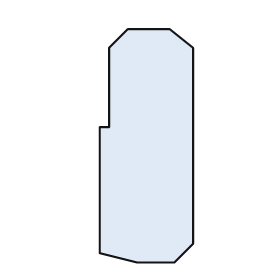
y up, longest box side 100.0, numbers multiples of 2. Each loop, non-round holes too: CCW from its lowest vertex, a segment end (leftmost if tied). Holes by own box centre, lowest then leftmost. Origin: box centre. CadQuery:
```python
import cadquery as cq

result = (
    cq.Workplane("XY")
    .moveTo(-4.0, -50.0)
    .lineTo(12.0, -50.0)
    .lineTo(20.0, -42.0)
    .lineTo(20.0, 42.0)
    .lineTo(10.0, 50.0)
    .lineTo(-8.0, 50.0)
    .lineTo(-16.0, 42.0)
    .lineTo(-16.0, 8.0)
    .lineTo(-20.0, 8.0)
    .lineTo(-20.0, -46.0)
    .close()
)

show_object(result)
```